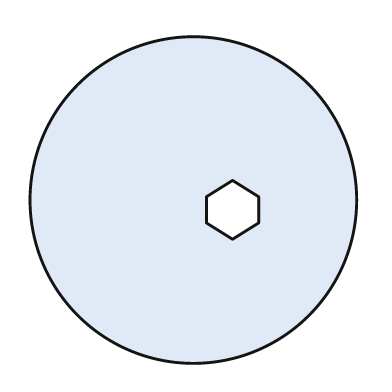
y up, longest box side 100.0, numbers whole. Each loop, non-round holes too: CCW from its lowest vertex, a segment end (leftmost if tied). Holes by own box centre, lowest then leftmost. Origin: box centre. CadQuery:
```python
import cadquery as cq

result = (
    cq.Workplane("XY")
    .moveTo(0.0, 0.0)
    .circle(50.0)
    .moveTo(12.0, -12.0)
    .lineTo(20.0, -7.0)
    .lineTo(20.0, 1.0)
    .lineTo(12.0, 6.0)
    .lineTo(4.0, 1.0)
    .lineTo(4.0, -7.0)
    .close()
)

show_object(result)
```